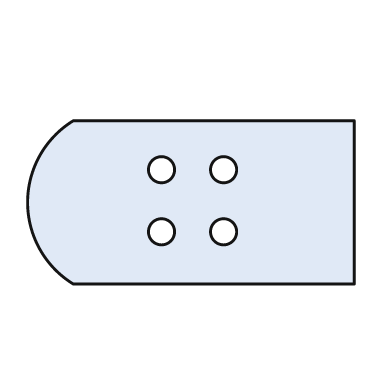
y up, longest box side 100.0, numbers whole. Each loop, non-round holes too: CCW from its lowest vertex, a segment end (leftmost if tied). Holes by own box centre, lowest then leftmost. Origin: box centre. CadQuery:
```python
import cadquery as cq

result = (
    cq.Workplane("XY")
    .moveTo(-36.0, -25.0)
    .lineTo(50.0, -25.0)
    .lineTo(50.0, 25.0)
    .lineTo(-36.0, 25.0)
    .threePointArc((-50.0, 0.0), (-36.0, -25.0))
    .close()
    .moveTo(-9.0, -9.0)
    .circle(4.0)
    .moveTo(10.0, -9.0)
    .circle(4.0)
    .moveTo(-9.0, 10.0)
    .circle(4.0)
    .moveTo(10.0, 10.0)
    .circle(4.0)
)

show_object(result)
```